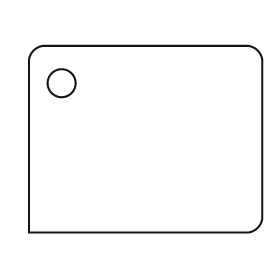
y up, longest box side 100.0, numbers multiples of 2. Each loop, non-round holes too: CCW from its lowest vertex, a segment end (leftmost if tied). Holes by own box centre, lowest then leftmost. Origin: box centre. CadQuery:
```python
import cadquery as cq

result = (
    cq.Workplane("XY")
    .moveTo(-50.0, -40.0)
    .lineTo(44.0, -40.0)
    .threePointArc((48.0, -38.0), (50.0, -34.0))
    .lineTo(50.0, 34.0)
    .threePointArc((48.0, 38.0), (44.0, 40.0))
    .lineTo(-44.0, 40.0)
    .threePointArc((-48.0, 38.0), (-50.0, 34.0))
    .close()
    .moveTo(-36.0, 24.0)
    .circle(6.0)
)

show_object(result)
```